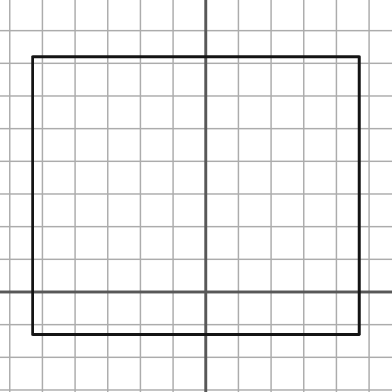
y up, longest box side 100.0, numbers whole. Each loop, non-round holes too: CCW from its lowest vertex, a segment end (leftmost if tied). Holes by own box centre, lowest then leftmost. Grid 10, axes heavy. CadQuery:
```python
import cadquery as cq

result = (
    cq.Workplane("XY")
    .moveTo(-53.0, -13.0)
    .lineTo(47.0, -13.0)
    .lineTo(47.0, 72.0)
    .lineTo(-53.0, 72.0)
    .close()
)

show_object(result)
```